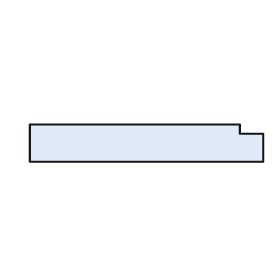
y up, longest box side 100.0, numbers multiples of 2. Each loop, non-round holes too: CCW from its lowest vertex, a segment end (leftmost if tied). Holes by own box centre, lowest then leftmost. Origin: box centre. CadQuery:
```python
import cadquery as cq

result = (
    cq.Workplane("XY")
    .moveTo(-50.0, -8.0)
    .lineTo(50.0, -8.0)
    .lineTo(50.0, 4.0)
    .lineTo(40.0, 4.0)
    .lineTo(40.0, 8.0)
    .lineTo(-50.0, 8.0)
    .close()
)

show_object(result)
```